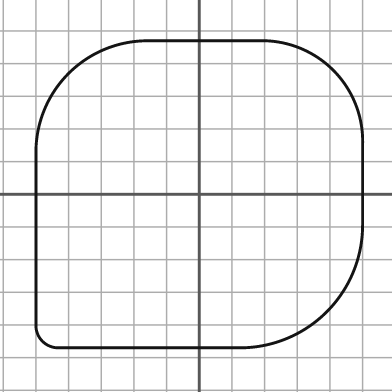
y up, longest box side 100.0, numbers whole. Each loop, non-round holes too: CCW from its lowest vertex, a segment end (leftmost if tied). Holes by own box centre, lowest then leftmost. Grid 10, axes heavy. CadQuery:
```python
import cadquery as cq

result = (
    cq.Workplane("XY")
    .moveTo(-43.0, -47.0)
    .lineTo(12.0, -47.0)
    .threePointArc((39.0, -36.0), (50.0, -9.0))
    .lineTo(50.0, 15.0)
    .threePointArc((41.0, 38.0), (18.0, 47.0))
    .lineTo(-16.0, 47.0)
    .threePointArc((-40.0, 37.0), (-50.0, 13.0))
    .lineTo(-50.0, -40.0)
    .threePointArc((-48.0, -45.0), (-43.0, -47.0))
    .close()
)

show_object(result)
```